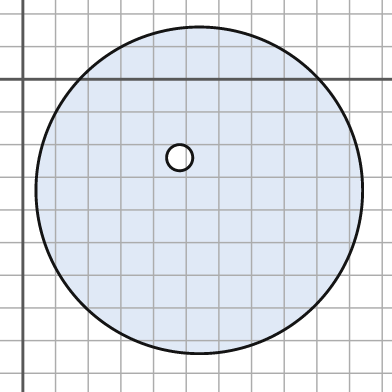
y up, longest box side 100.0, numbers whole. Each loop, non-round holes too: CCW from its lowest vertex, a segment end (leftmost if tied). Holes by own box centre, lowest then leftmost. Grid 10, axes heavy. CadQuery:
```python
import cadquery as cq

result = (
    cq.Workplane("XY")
    .moveTo(54.0, -34.0)
    .circle(50.0)
    .moveTo(48.0, -24.0)
    .circle(4.0)
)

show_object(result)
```